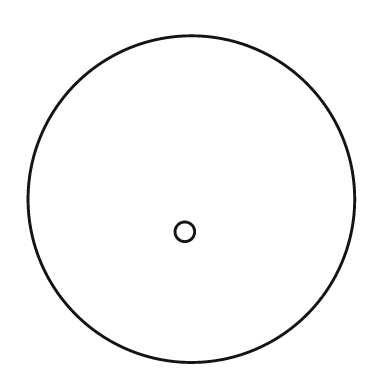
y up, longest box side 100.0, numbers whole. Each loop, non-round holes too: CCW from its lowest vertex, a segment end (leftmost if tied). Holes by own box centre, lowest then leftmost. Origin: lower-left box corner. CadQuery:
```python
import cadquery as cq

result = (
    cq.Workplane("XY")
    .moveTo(50.0, 50.0)
    .circle(50.0)
    .moveTo(48.0, 40.0)
    .circle(3.0)
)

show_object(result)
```